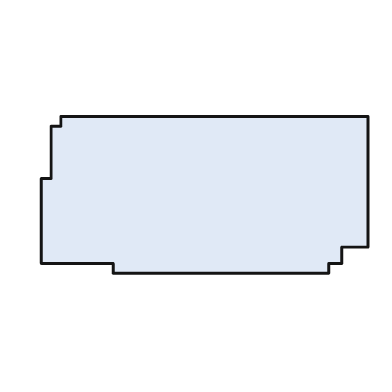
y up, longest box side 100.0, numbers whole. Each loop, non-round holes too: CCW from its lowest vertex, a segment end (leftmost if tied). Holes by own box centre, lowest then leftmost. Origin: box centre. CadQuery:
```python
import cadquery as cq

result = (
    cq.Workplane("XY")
    .moveTo(-28.0, -24.0)
    .lineTo(38.0, -24.0)
    .lineTo(38.0, -21.0)
    .lineTo(42.0, -21.0)
    .lineTo(42.0, -16.0)
    .lineTo(50.0, -16.0)
    .lineTo(50.0, 24.0)
    .lineTo(-44.0, 24.0)
    .lineTo(-44.0, 21.0)
    .lineTo(-47.0, 21.0)
    .lineTo(-47.0, 5.0)
    .lineTo(-50.0, 5.0)
    .lineTo(-50.0, -21.0)
    .lineTo(-28.0, -21.0)
    .close()
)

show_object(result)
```